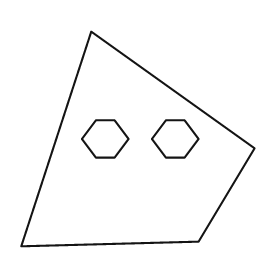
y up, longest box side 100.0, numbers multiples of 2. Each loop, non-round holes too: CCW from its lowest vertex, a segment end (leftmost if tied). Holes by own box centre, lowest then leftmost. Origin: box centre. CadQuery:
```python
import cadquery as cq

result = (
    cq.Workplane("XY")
    .moveTo(-50.0, -46.0)
    .lineTo(26.0, -44.0)
    .lineTo(50.0, -4.0)
    .lineTo(-20.0, 46.0)
    .close()
    .moveTo(-18.0, -8.0)
    .lineTo(-10.0, -8.0)
    .lineTo(-4.0, 0.0)
    .lineTo(-10.0, 8.0)
    .lineTo(-18.0, 8.0)
    .lineTo(-24.0, 0.0)
    .close()
    .moveTo(12.0, -8.0)
    .lineTo(20.0, -8.0)
    .lineTo(26.0, 0.0)
    .lineTo(20.0, 8.0)
    .lineTo(12.0, 8.0)
    .lineTo(6.0, 0.0)
    .close()
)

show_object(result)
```